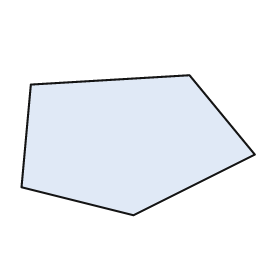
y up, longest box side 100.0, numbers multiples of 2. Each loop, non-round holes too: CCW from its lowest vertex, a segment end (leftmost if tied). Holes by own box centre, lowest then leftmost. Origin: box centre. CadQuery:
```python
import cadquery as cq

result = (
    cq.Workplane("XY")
    .moveTo(-2.0, -30.0)
    .lineTo(50.0, -4.0)
    .lineTo(22.0, 30.0)
    .lineTo(-46.0, 26.0)
    .lineTo(-50.0, -18.0)
    .close()
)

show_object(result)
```